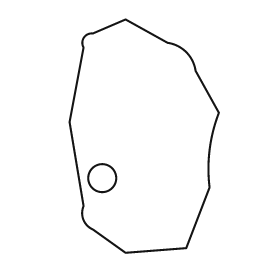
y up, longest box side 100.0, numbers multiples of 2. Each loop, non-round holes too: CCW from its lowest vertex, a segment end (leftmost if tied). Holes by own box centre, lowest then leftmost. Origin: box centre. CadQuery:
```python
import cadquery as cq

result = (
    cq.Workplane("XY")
    .moveTo(-8.0, -50.0)
    .lineTo(18.0, -48.0)
    .lineTo(28.0, -22.0)
    .threePointArc((28.0, -6.0), (32.0, 10.0))
    .lineTo(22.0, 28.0)
    .threePointArc((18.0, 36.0), (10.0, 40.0))
    .lineTo(-8.0, 50.0)
    .lineTo(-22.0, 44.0)
    .threePointArc((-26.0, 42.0), (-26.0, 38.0))
    .lineTo(-32.0, 6.0)
    .lineTo(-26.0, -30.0)
    .threePointArc((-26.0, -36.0), (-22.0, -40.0))
    .close()
    .moveTo(-18.0, -18.0)
    .circle(6.0)
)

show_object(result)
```